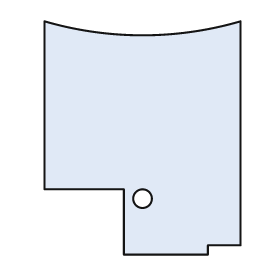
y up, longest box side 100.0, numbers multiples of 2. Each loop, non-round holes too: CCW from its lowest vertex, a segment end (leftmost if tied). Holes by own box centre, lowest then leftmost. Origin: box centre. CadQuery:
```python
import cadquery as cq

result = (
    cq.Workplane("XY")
    .moveTo(-8.0, -50.0)
    .lineTo(28.0, -50.0)
    .lineTo(28.0, -46.0)
    .lineTo(42.0, -46.0)
    .lineTo(42.0, 50.0)
    .threePointArc((0.0, 44.0), (-42.0, 50.0))
    .lineTo(-42.0, -22.0)
    .lineTo(-8.0, -22.0)
    .close()
    .moveTo(0.0, -26.0)
    .circle(4.0)
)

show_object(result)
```